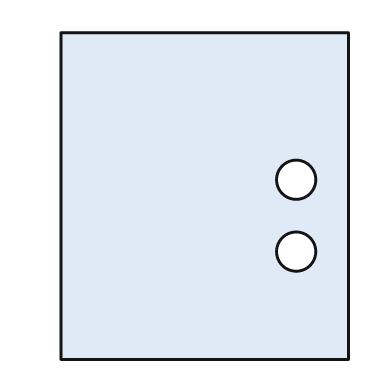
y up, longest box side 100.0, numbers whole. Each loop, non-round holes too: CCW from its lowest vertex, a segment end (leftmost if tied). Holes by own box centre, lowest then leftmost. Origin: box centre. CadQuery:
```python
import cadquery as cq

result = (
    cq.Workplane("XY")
    .moveTo(-44.0, -50.0)
    .lineTo(44.0, -50.0)
    .lineTo(44.0, 50.0)
    .lineTo(-44.0, 50.0)
    .close()
    .moveTo(28.0, -17.0)
    .circle(6.0)
    .moveTo(28.0, 5.0)
    .circle(6.0)
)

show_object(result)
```